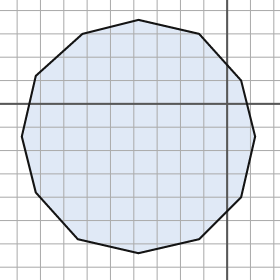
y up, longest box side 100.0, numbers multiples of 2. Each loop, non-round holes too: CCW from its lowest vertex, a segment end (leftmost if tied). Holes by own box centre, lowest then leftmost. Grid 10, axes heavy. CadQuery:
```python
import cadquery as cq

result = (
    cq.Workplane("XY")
    .moveTo(-38.0, -64.0)
    .lineTo(-12.0, -58.0)
    .lineTo(6.0, -40.0)
    .lineTo(12.0, -14.0)
    .lineTo(6.0, 10.0)
    .lineTo(-12.0, 30.0)
    .lineTo(-38.0, 36.0)
    .lineTo(-62.0, 30.0)
    .lineTo(-82.0, 12.0)
    .lineTo(-88.0, -14.0)
    .lineTo(-82.0, -38.0)
    .lineTo(-64.0, -58.0)
    .close()
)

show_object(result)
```